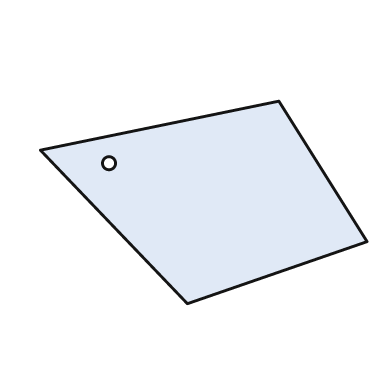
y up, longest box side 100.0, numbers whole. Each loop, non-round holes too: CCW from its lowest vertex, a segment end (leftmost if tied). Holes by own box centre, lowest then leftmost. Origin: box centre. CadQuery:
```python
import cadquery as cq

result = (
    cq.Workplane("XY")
    .moveTo(-5.0, -31.0)
    .lineTo(50.0, -12.0)
    .lineTo(23.0, 31.0)
    .lineTo(-50.0, 16.0)
    .close()
    .moveTo(-29.0, 12.0)
    .circle(2.0)
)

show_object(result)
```